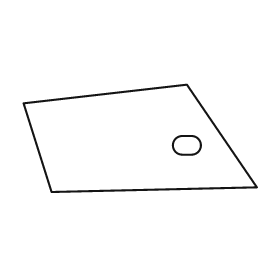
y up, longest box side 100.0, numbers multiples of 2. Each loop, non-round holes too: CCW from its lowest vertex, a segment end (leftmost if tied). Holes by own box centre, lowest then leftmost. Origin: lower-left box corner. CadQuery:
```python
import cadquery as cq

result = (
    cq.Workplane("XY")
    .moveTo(12.0, 0.0)
    .lineTo(100.0, 2.0)
    .lineTo(70.0, 46.0)
    .lineTo(0.0, 38.0)
    .close()
    .moveTo(68.0, 16.0)
    .lineTo(72.0, 16.0)
    .threePointArc((76.0, 20.0), (72.0, 24.0))
    .lineTo(68.0, 24.0)
    .threePointArc((64.0, 20.0), (68.0, 16.0))
    .close()
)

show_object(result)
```